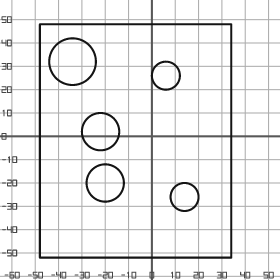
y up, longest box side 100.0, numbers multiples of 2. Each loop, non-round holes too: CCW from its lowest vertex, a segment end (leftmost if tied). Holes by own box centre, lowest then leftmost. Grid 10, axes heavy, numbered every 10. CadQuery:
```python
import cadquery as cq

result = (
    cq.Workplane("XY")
    .moveTo(-48.0, -52.0)
    .lineTo(34.0, -52.0)
    .lineTo(34.0, 48.0)
    .lineTo(-48.0, 48.0)
    .close()
    .moveTo(14.0, -26.0)
    .circle(6.0)
    .moveTo(-20.0, -20.0)
    .circle(8.0)
    .moveTo(-22.0, 2.0)
    .circle(8.0)
    .moveTo(6.0, 26.0)
    .circle(6.0)
    .moveTo(-34.0, 32.0)
    .circle(10.0)
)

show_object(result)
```